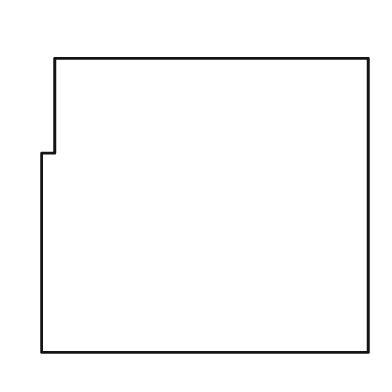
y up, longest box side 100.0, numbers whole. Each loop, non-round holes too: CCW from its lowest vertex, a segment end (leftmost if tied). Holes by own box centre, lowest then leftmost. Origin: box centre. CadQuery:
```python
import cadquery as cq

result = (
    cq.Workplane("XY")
    .moveTo(-50.0, -45.0)
    .lineTo(50.0, -45.0)
    .lineTo(50.0, 45.0)
    .lineTo(-46.0, 45.0)
    .lineTo(-46.0, 16.0)
    .lineTo(-50.0, 16.0)
    .close()
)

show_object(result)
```